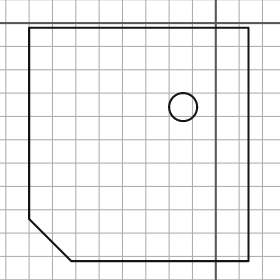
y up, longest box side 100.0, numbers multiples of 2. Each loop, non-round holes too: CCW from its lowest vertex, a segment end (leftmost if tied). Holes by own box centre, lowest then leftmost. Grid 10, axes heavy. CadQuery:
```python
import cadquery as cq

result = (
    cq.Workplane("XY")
    .moveTo(-62.0, -102.0)
    .lineTo(14.0, -102.0)
    .lineTo(14.0, -2.0)
    .lineTo(-80.0, -2.0)
    .lineTo(-80.0, -84.0)
    .close()
    .moveTo(-14.0, -36.0)
    .circle(6.0)
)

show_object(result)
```